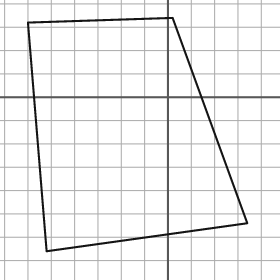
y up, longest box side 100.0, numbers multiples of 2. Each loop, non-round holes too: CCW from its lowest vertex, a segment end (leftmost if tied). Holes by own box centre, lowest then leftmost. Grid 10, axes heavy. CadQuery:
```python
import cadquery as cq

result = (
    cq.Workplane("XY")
    .moveTo(-52.0, -66.0)
    .lineTo(34.0, -54.0)
    .lineTo(2.0, 34.0)
    .lineTo(-60.0, 32.0)
    .close()
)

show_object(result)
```